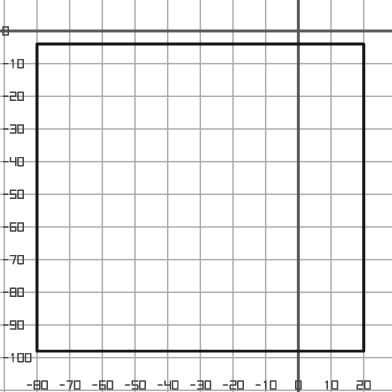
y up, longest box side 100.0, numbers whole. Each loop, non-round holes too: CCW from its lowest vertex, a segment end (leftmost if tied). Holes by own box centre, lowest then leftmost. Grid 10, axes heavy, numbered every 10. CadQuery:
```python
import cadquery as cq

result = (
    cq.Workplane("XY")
    .moveTo(-80.0, -98.0)
    .lineTo(20.0, -98.0)
    .lineTo(20.0, -4.0)
    .lineTo(-80.0, -4.0)
    .close()
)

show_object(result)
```